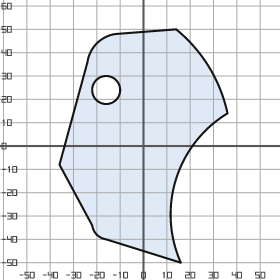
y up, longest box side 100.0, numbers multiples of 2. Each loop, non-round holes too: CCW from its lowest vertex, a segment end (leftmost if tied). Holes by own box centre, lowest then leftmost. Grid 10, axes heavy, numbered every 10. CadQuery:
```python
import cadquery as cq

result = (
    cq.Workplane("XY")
    .moveTo(16.0, -50.0)
    .threePointArc((14.0, -14.0), (36.0, 14.0))
    .threePointArc((28.0, 34.0), (14.0, 50.0))
    .lineTo(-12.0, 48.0)
    .threePointArc((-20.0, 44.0), (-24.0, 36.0))
    .lineTo(-36.0, -8.0)
    .lineTo(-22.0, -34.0)
    .threePointArc((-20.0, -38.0), (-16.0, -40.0))
    .close()
    .moveTo(-16.0, 24.0)
    .circle(6.0)
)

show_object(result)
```